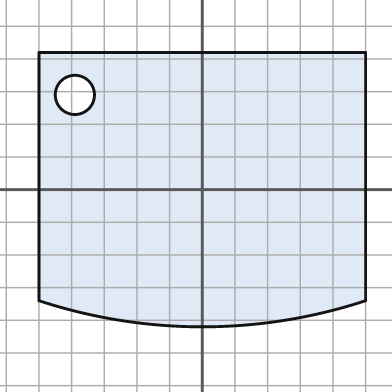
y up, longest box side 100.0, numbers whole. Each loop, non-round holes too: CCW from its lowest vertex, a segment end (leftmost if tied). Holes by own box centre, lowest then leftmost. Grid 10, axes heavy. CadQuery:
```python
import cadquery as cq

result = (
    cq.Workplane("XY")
    .moveTo(-50.0, -34.0)
    .threePointArc((0.0, -42.0), (50.0, -34.0))
    .lineTo(50.0, 42.0)
    .lineTo(-50.0, 42.0)
    .close()
    .moveTo(-39.0, 29.0)
    .circle(6.0)
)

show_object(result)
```